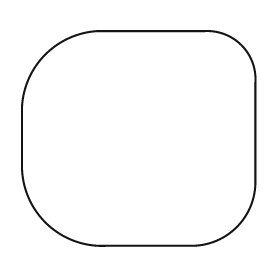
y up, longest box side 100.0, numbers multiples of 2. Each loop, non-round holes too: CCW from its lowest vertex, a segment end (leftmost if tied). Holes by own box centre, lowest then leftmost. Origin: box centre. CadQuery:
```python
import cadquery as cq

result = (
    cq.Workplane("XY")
    .moveTo(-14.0, -46.0)
    .lineTo(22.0, -46.0)
    .threePointArc((42.0, -38.0), (50.0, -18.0))
    .lineTo(50.0, 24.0)
    .threePointArc((44.0, 40.0), (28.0, 46.0))
    .lineTo(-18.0, 46.0)
    .threePointArc((-40.0, 36.0), (-50.0, 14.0))
    .lineTo(-50.0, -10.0)
    .threePointArc((-40.0, -36.0), (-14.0, -46.0))
    .close()
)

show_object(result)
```